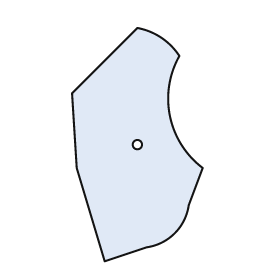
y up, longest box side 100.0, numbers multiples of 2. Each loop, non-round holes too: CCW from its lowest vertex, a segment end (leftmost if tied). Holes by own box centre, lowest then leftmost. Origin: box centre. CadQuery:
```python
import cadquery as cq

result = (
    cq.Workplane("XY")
    .moveTo(-14.0, -50.0)
    .lineTo(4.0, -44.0)
    .threePointArc((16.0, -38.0), (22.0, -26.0))
    .lineTo(28.0, -10.0)
    .threePointArc((14.0, 12.0), (18.0, 38.0))
    .threePointArc((10.0, 46.0), (0.0, 50.0))
    .lineTo(-28.0, 22.0)
    .lineTo(-26.0, -10.0)
    .close()
    .moveTo(0.0, 0.0)
    .circle(2.0)
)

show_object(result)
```